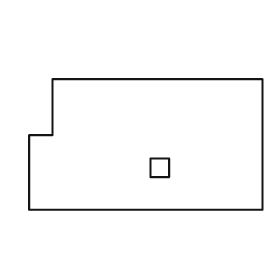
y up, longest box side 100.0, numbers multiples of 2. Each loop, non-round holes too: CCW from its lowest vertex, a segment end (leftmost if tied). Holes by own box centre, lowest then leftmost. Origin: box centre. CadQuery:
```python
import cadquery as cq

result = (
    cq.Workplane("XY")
    .moveTo(-50.0, -28.0)
    .lineTo(50.0, -28.0)
    .lineTo(50.0, 28.0)
    .lineTo(-40.0, 28.0)
    .lineTo(-40.0, 4.0)
    .lineTo(-50.0, 4.0)
    .close()
    .moveTo(2.0, -14.0)
    .lineTo(10.0, -14.0)
    .lineTo(10.0, -6.0)
    .lineTo(2.0, -6.0)
    .close()
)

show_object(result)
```